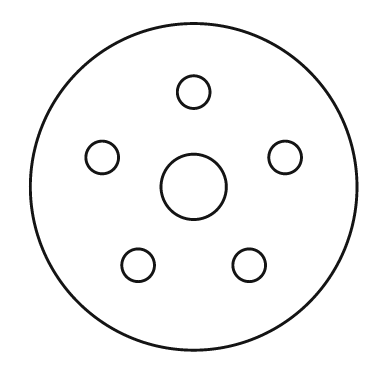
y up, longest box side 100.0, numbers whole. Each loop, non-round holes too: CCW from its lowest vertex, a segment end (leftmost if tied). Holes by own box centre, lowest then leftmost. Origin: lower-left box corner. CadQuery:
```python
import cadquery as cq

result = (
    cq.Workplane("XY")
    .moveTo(50.0, 50.0)
    .circle(50.0)
    .moveTo(33.0, 26.0)
    .circle(5.0)
    .moveTo(67.0, 26.0)
    .circle(5.0)
    .moveTo(50.0, 50.0)
    .circle(10.0)
    .moveTo(22.0, 59.0)
    .circle(5.0)
    .moveTo(78.0, 59.0)
    .circle(5.0)
    .moveTo(50.0, 79.0)
    .circle(5.0)
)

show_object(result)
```